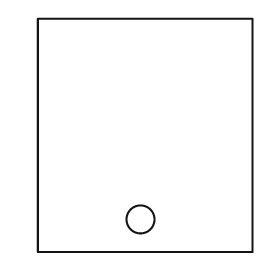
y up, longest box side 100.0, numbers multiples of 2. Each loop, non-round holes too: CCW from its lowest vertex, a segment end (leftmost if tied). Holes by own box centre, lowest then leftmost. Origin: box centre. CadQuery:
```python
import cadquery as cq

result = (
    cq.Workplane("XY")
    .moveTo(-46.0, -50.0)
    .lineTo(46.0, -50.0)
    .lineTo(46.0, 50.0)
    .lineTo(-46.0, 50.0)
    .close()
    .moveTo(-2.0, -36.0)
    .circle(6.0)
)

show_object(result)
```